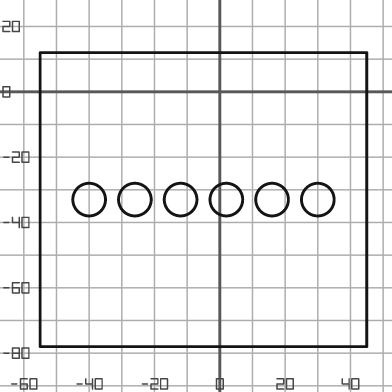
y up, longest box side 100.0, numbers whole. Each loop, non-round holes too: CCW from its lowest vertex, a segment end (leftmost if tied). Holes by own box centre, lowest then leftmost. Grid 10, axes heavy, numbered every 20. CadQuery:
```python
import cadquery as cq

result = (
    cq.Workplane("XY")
    .moveTo(-55.0, -78.0)
    .lineTo(45.0, -78.0)
    .lineTo(45.0, 12.0)
    .lineTo(-55.0, 12.0)
    .close()
    .moveTo(-40.0, -33.0)
    .circle(5.0)
    .moveTo(-26.0, -33.0)
    .circle(5.0)
    .moveTo(-12.0, -33.0)
    .circle(5.0)
    .moveTo(2.0, -33.0)
    .circle(5.0)
    .moveTo(16.0, -33.0)
    .circle(5.0)
    .moveTo(30.0, -33.0)
    .circle(5.0)
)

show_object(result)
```